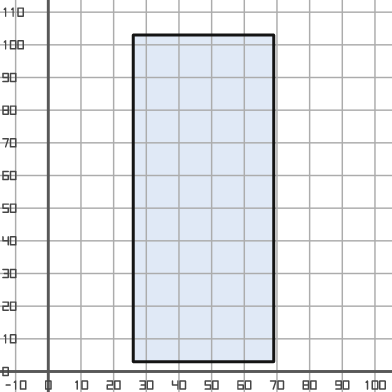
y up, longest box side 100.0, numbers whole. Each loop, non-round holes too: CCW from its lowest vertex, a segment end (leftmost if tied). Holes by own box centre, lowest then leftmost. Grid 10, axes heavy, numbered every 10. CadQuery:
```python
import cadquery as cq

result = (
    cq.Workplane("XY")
    .moveTo(26.0, 3.0)
    .lineTo(69.0, 3.0)
    .lineTo(69.0, 103.0)
    .lineTo(26.0, 103.0)
    .close()
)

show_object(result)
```